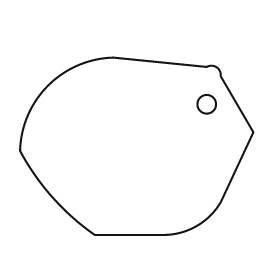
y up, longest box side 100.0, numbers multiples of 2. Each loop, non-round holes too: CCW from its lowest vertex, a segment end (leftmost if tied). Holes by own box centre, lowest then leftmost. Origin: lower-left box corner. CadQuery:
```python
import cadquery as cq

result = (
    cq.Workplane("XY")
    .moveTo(32.0, 0.0)
    .lineTo(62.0, 0.0)
    .threePointArc((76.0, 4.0), (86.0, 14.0))
    .lineTo(100.0, 44.0)
    .lineTo(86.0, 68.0)
    .threePointArc((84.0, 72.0), (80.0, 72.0))
    .lineTo(40.0, 76.0)
    .threePointArc((12.0, 64.0), (0.0, 36.0))
    .threePointArc((14.0, 16.0), (32.0, 0.0))
    .close()
    .moveTo(80.0, 56.0)
    .circle(4.0)
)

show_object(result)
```